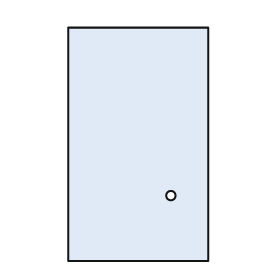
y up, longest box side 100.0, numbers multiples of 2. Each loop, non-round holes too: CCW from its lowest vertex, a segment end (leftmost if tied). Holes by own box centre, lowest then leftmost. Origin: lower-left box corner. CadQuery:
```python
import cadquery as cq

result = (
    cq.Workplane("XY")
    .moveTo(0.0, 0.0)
    .lineTo(60.0, 0.0)
    .lineTo(60.0, 100.0)
    .lineTo(0.0, 100.0)
    .close()
    .moveTo(44.0, 28.0)
    .circle(2.0)
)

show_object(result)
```